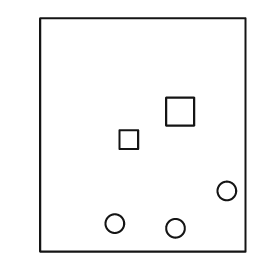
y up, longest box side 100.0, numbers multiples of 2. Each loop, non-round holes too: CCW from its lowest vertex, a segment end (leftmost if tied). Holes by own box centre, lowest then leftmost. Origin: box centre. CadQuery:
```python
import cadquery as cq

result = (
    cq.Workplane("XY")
    .moveTo(-44.0, -50.0)
    .lineTo(44.0, -50.0)
    .lineTo(44.0, 50.0)
    .lineTo(-44.0, 50.0)
    .close()
    .moveTo(14.0, -40.0)
    .circle(4.0)
    .moveTo(-12.0, -38.0)
    .circle(4.0)
    .moveTo(36.0, -24.0)
    .circle(4.0)
    .moveTo(-10.0, -6.0)
    .lineTo(-2.0, -6.0)
    .lineTo(-2.0, 2.0)
    .lineTo(-10.0, 2.0)
    .close()
    .moveTo(10.0, 4.0)
    .lineTo(22.0, 4.0)
    .lineTo(22.0, 16.0)
    .lineTo(10.0, 16.0)
    .close()
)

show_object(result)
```